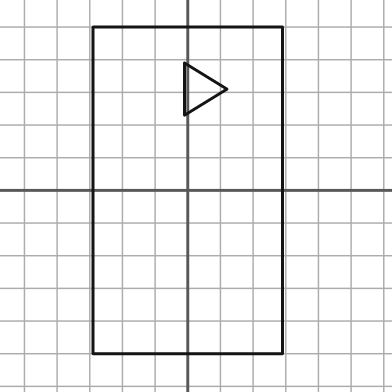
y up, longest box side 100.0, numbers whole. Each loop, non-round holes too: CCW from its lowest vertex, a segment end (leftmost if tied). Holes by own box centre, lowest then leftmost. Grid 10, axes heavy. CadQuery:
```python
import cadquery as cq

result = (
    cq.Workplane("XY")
    .moveTo(-29.0, -50.0)
    .lineTo(29.0, -50.0)
    .lineTo(29.0, 50.0)
    .lineTo(-29.0, 50.0)
    .close()
    .moveTo(-1.0, 23.0)
    .lineTo(12.0, 31.0)
    .lineTo(-1.0, 39.0)
    .close()
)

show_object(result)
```